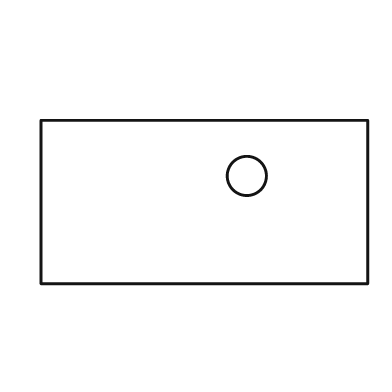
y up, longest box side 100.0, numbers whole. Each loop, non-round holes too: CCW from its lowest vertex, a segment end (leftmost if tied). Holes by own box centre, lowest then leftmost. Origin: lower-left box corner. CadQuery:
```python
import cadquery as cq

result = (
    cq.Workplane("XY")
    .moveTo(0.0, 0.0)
    .lineTo(100.0, 0.0)
    .lineTo(100.0, 50.0)
    .lineTo(0.0, 50.0)
    .close()
    .moveTo(63.0, 33.0)
    .circle(6.0)
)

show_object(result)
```